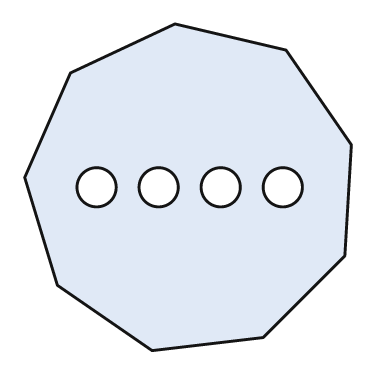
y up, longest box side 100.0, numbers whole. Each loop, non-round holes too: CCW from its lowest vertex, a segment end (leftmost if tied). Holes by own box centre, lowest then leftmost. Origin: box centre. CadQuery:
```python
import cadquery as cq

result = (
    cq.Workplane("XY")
    .moveTo(-11.0, -50.0)
    .lineTo(23.0, -46.0)
    .lineTo(48.0, -21.0)
    .lineTo(50.0, 13.0)
    .lineTo(30.0, 42.0)
    .lineTo(-4.0, 50.0)
    .lineTo(-36.0, 35.0)
    .lineTo(-50.0, 3.0)
    .lineTo(-40.0, -30.0)
    .close()
    .moveTo(-28.0, 0.0)
    .circle(6.0)
    .moveTo(-9.0, 0.0)
    .circle(6.0)
    .moveTo(10.0, 0.0)
    .circle(6.0)
    .moveTo(29.0, 0.0)
    .circle(6.0)
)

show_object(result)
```